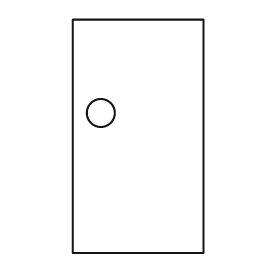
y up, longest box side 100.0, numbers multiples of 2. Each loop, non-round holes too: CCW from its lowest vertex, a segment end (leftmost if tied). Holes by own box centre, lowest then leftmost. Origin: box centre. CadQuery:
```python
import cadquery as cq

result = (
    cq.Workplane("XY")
    .moveTo(-28.0, -50.0)
    .lineTo(28.0, -50.0)
    .lineTo(28.0, 50.0)
    .lineTo(-28.0, 50.0)
    .close()
    .moveTo(-16.0, 10.0)
    .circle(6.0)
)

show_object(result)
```